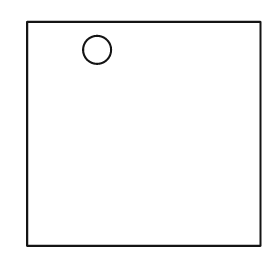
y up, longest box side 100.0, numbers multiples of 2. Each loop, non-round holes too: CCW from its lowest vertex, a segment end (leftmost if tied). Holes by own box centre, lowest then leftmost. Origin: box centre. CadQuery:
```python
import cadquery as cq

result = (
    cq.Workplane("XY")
    .moveTo(-50.0, -48.0)
    .lineTo(50.0, -48.0)
    .lineTo(50.0, 48.0)
    .lineTo(-50.0, 48.0)
    .close()
    .moveTo(-20.0, 36.0)
    .circle(6.0)
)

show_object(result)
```